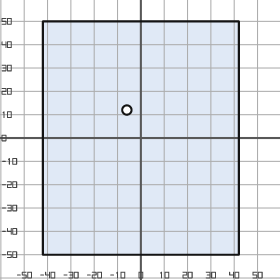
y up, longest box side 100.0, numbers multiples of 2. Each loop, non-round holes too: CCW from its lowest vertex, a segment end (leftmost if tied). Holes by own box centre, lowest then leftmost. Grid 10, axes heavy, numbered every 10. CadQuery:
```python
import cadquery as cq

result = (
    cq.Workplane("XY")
    .moveTo(-42.0, -50.0)
    .lineTo(42.0, -50.0)
    .lineTo(42.0, 50.0)
    .lineTo(-42.0, 50.0)
    .close()
    .moveTo(-6.0, 12.0)
    .circle(2.0)
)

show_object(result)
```